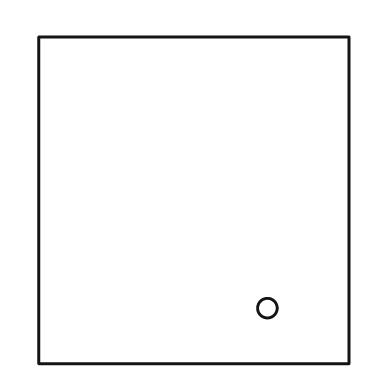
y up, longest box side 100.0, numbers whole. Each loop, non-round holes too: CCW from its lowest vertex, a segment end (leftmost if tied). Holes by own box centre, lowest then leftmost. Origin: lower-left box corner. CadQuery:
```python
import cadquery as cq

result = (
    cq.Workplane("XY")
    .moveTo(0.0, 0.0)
    .lineTo(95.0, 0.0)
    .lineTo(95.0, 100.0)
    .lineTo(0.0, 100.0)
    .close()
    .moveTo(70.0, 17.0)
    .circle(3.0)
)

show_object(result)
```